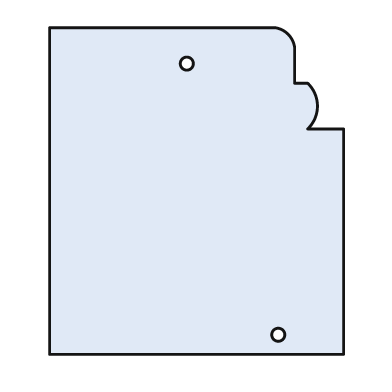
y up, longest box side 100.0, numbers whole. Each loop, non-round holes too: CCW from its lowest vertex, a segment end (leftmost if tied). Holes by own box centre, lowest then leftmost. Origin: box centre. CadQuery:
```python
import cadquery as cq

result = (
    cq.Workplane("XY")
    .moveTo(-45.0, -50.0)
    .lineTo(45.0, -50.0)
    .lineTo(45.0, 19.0)
    .lineTo(34.0, 19.0)
    .threePointArc((37.0, 26.0), (34.0, 33.0))
    .lineTo(30.0, 33.0)
    .lineTo(30.0, 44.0)
    .threePointArc((28.0, 48.0), (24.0, 50.0))
    .lineTo(-45.0, 50.0)
    .close()
    .moveTo(25.0, -44.0)
    .circle(2.0)
    .moveTo(-3.0, 39.0)
    .circle(2.0)
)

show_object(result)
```